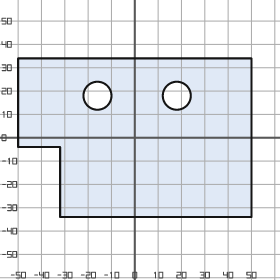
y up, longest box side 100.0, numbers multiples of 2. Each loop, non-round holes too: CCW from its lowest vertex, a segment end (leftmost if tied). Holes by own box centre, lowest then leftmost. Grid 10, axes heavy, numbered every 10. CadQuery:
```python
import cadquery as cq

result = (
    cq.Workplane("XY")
    .moveTo(-32.0, -34.0)
    .lineTo(50.0, -34.0)
    .lineTo(50.0, 34.0)
    .lineTo(-50.0, 34.0)
    .lineTo(-50.0, -4.0)
    .lineTo(-32.0, -4.0)
    .close()
    .moveTo(-16.0, 18.0)
    .circle(6.0)
    .moveTo(18.0, 18.0)
    .circle(6.0)
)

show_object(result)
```